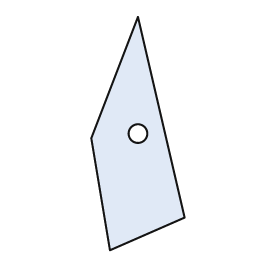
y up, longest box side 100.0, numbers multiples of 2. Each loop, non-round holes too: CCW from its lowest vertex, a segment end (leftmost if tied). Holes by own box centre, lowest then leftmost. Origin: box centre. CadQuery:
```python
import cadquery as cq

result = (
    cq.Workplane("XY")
    .moveTo(-12.0, -50.0)
    .lineTo(20.0, -36.0)
    .lineTo(0.0, 50.0)
    .lineTo(-20.0, -2.0)
    .close()
    .moveTo(0.0, 0.0)
    .circle(4.0)
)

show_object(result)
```